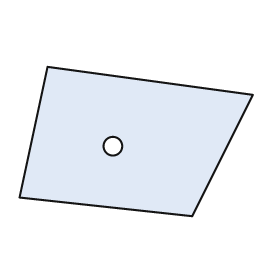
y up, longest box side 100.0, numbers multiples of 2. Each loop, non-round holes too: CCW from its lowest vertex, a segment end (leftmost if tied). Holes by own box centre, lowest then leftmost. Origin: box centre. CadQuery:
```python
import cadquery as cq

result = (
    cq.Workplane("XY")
    .moveTo(24.0, -32.0)
    .lineTo(50.0, 20.0)
    .lineTo(-38.0, 32.0)
    .lineTo(-50.0, -24.0)
    .close()
    .moveTo(-10.0, -2.0)
    .circle(4.0)
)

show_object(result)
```